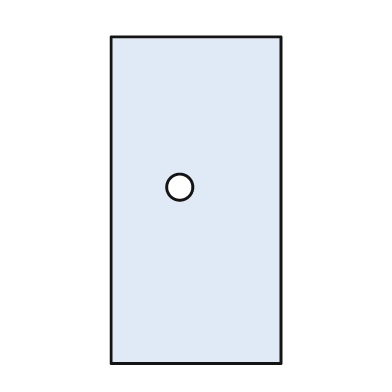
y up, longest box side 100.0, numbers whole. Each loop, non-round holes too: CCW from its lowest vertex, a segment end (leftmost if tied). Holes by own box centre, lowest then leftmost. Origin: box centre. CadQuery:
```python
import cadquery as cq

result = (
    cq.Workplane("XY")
    .moveTo(-26.0, -50.0)
    .lineTo(26.0, -50.0)
    .lineTo(26.0, 50.0)
    .lineTo(-26.0, 50.0)
    .close()
    .moveTo(-5.0, 4.0)
    .circle(4.0)
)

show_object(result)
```